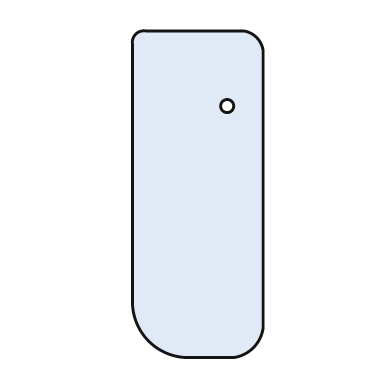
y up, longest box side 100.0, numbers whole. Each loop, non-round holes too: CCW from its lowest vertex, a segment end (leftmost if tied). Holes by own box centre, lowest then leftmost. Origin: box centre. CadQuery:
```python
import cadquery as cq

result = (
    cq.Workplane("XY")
    .moveTo(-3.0, -50.0)
    .lineTo(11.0, -50.0)
    .threePointArc((17.0, -47.0), (20.0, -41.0))
    .lineTo(20.0, 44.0)
    .threePointArc((18.0, 48.0), (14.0, 50.0))
    .lineTo(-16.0, 50.0)
    .threePointArc((-19.0, 49.0), (-20.0, 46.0))
    .lineTo(-20.0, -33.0)
    .threePointArc((-15.0, -45.0), (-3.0, -50.0))
    .close()
    .moveTo(9.0, 27.0)
    .circle(2.0)
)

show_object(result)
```